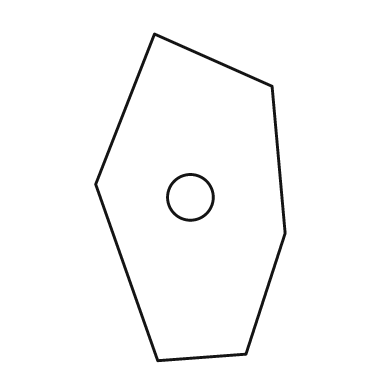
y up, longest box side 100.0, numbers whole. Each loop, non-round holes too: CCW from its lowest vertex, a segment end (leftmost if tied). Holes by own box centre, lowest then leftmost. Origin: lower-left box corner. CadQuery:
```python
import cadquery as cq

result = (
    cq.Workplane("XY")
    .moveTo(19.0, 0.0)
    .lineTo(46.0, 2.0)
    .lineTo(58.0, 39.0)
    .lineTo(54.0, 84.0)
    .lineTo(18.0, 100.0)
    .lineTo(0.0, 54.0)
    .close()
    .moveTo(29.0, 50.0)
    .circle(7.0)
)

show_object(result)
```